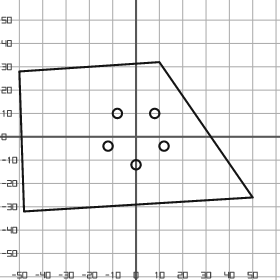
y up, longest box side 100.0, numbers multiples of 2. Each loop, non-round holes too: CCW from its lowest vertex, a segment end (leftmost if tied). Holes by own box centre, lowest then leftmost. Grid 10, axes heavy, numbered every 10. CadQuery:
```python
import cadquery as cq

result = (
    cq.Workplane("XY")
    .moveTo(-48.0, -32.0)
    .lineTo(50.0, -26.0)
    .lineTo(10.0, 32.0)
    .lineTo(-50.0, 28.0)
    .close()
    .moveTo(0.0, -12.0)
    .circle(2.0)
    .moveTo(-12.0, -4.0)
    .circle(2.0)
    .moveTo(12.0, -4.0)
    .circle(2.0)
    .moveTo(-8.0, 10.0)
    .circle(2.0)
    .moveTo(8.0, 10.0)
    .circle(2.0)
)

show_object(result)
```